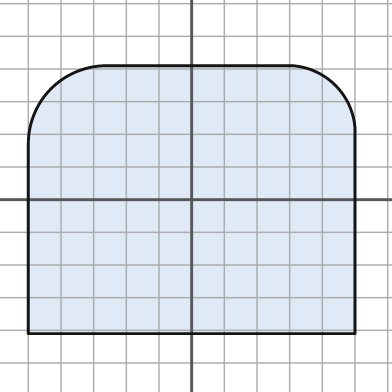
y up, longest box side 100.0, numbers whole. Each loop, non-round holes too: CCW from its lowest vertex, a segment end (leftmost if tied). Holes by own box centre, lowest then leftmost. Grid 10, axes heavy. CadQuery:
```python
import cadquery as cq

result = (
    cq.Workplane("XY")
    .moveTo(-50.0, -41.0)
    .lineTo(50.0, -41.0)
    .lineTo(50.0, 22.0)
    .threePointArc((44.0, 35.0), (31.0, 41.0))
    .lineTo(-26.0, 41.0)
    .threePointArc((-43.0, 34.0), (-50.0, 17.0))
    .close()
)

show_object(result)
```